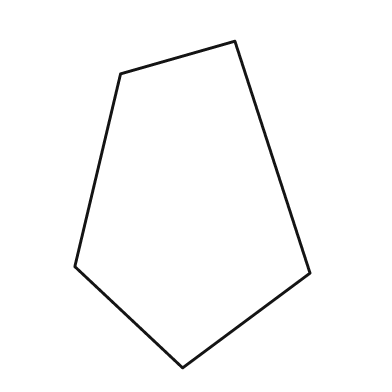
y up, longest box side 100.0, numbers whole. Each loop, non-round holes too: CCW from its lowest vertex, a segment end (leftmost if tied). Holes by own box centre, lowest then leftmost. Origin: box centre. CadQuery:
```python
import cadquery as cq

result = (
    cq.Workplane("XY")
    .moveTo(-3.0, -50.0)
    .lineTo(36.0, -21.0)
    .lineTo(13.0, 50.0)
    .lineTo(-22.0, 40.0)
    .lineTo(-36.0, -19.0)
    .close()
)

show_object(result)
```